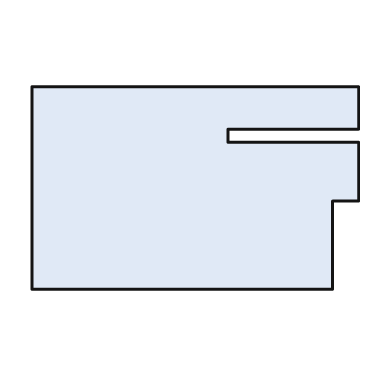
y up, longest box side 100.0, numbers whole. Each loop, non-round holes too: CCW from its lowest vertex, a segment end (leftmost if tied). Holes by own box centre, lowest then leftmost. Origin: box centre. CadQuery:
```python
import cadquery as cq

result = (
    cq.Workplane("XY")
    .moveTo(-50.0, -31.0)
    .lineTo(42.0, -31.0)
    .lineTo(42.0, -4.0)
    .lineTo(50.0, -4.0)
    .lineTo(50.0, 14.0)
    .lineTo(10.0, 14.0)
    .lineTo(10.0, 18.0)
    .lineTo(50.0, 18.0)
    .lineTo(50.0, 31.0)
    .lineTo(-50.0, 31.0)
    .close()
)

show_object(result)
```